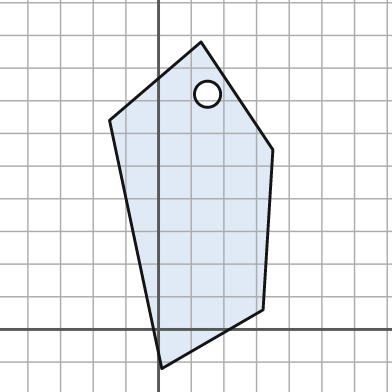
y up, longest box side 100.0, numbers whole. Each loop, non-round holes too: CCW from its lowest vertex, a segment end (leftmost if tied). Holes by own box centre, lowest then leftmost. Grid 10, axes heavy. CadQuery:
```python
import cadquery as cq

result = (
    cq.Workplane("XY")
    .moveTo(1.0, -12.0)
    .lineTo(32.0, 6.0)
    .lineTo(35.0, 55.0)
    .lineTo(13.0, 88.0)
    .lineTo(-15.0, 64.0)
    .close()
    .moveTo(15.0, 72.0)
    .circle(4.0)
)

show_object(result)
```